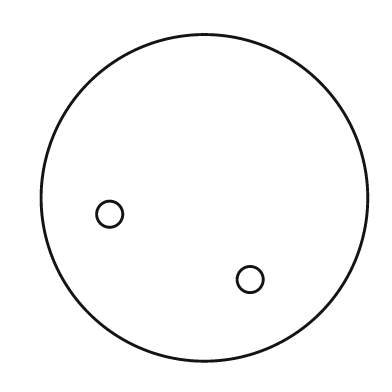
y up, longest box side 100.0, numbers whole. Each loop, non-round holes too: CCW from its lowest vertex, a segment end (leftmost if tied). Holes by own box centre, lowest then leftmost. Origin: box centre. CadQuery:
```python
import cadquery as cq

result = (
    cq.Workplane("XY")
    .moveTo(0.0, 0.0)
    .circle(50.0)
    .moveTo(14.0, -25.0)
    .circle(4.0)
    .moveTo(-29.0, -5.0)
    .circle(4.0)
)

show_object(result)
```